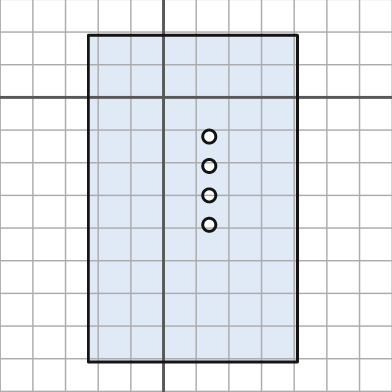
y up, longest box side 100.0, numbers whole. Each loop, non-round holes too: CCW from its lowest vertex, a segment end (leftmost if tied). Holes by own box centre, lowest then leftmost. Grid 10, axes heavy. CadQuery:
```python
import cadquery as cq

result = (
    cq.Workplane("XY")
    .moveTo(-23.0, -81.0)
    .lineTo(41.0, -81.0)
    .lineTo(41.0, 19.0)
    .lineTo(-23.0, 19.0)
    .close()
    .moveTo(14.0, -39.0)
    .circle(2.0)
    .moveTo(14.0, -30.0)
    .circle(2.0)
    .moveTo(14.0, -21.0)
    .circle(2.0)
    .moveTo(14.0, -12.0)
    .circle(2.0)
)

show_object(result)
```